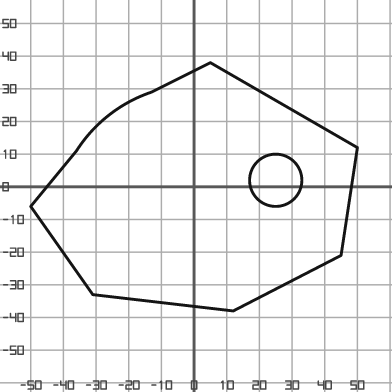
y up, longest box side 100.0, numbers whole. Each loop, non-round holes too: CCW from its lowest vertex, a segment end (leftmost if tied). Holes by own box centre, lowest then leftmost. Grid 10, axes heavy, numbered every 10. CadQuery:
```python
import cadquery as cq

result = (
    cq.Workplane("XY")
    .moveTo(12.0, -38.0)
    .lineTo(45.0, -21.0)
    .lineTo(50.0, 12.0)
    .lineTo(5.0, 38.0)
    .lineTo(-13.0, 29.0)
    .threePointArc((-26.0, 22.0), (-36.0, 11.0))
    .lineTo(-50.0, -6.0)
    .lineTo(-31.0, -33.0)
    .close()
    .moveTo(25.0, 2.0)
    .circle(8.0)
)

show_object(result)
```